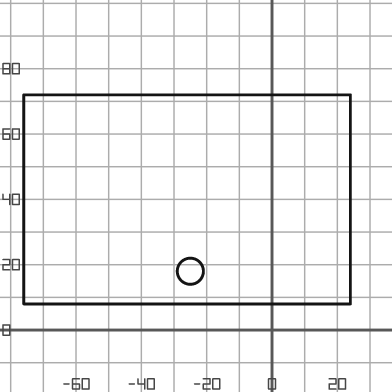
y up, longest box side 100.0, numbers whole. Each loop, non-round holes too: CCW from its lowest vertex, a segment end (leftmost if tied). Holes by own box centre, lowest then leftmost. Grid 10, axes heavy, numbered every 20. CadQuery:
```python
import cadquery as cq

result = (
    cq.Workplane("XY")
    .moveTo(-76.0, 8.0)
    .lineTo(24.0, 8.0)
    .lineTo(24.0, 72.0)
    .lineTo(-76.0, 72.0)
    .close()
    .moveTo(-25.0, 18.0)
    .circle(4.0)
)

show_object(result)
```